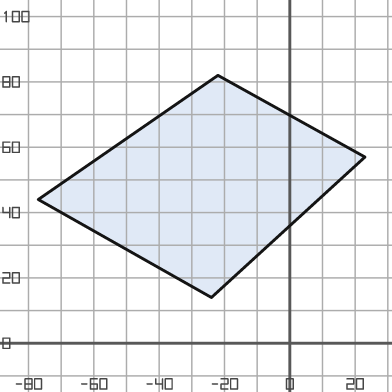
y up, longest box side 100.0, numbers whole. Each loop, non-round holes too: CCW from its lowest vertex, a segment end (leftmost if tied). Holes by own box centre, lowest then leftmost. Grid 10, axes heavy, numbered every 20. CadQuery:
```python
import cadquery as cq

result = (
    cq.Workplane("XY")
    .moveTo(-24.0, 14.0)
    .lineTo(23.0, 57.0)
    .lineTo(-22.0, 82.0)
    .lineTo(-77.0, 44.0)
    .close()
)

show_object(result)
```